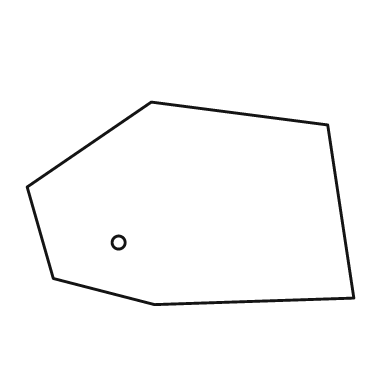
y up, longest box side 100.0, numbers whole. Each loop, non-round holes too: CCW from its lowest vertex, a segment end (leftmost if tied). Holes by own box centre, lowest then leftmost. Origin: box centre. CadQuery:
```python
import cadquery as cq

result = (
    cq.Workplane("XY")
    .moveTo(-11.0, -31.0)
    .lineTo(50.0, -29.0)
    .lineTo(42.0, 24.0)
    .lineTo(-12.0, 31.0)
    .lineTo(-50.0, 5.0)
    .lineTo(-42.0, -23.0)
    .close()
    .moveTo(-22.0, -12.0)
    .circle(2.0)
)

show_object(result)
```